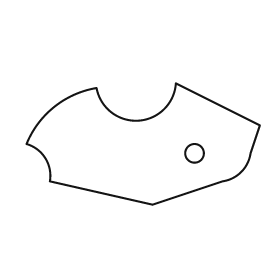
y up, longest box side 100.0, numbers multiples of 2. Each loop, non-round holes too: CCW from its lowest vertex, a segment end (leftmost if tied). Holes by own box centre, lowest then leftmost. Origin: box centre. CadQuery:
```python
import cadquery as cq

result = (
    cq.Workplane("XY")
    .moveTo(4.0, -26.0)
    .lineTo(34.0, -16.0)
    .threePointArc((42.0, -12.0), (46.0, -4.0))
    .lineTo(50.0, 8.0)
    .lineTo(14.0, 26.0)
    .threePointArc((-2.0, 10.0), (-20.0, 24.0))
    .threePointArc((-38.0, 16.0), (-50.0, 0.0))
    .threePointArc((-42.0, -6.0), (-40.0, -16.0))
    .close()
    .moveTo(22.0, -4.0)
    .circle(4.0)
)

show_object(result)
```